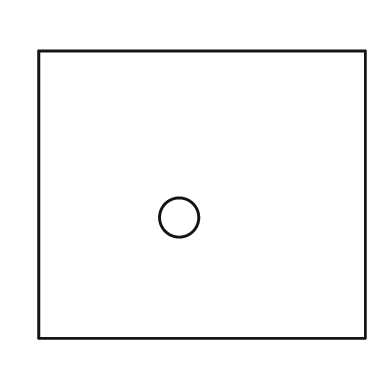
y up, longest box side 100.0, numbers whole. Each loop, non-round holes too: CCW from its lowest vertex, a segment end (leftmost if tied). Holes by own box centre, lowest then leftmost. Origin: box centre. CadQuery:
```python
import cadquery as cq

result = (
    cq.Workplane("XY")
    .moveTo(-50.0, -44.0)
    .lineTo(50.0, -44.0)
    .lineTo(50.0, 44.0)
    .lineTo(-50.0, 44.0)
    .close()
    .moveTo(-7.0, -7.0)
    .circle(6.0)
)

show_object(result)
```